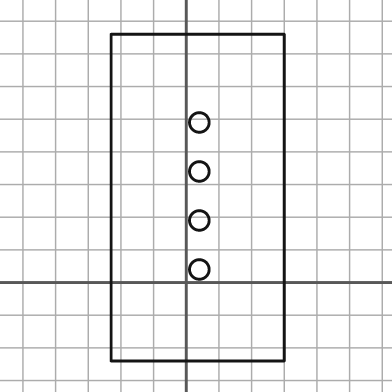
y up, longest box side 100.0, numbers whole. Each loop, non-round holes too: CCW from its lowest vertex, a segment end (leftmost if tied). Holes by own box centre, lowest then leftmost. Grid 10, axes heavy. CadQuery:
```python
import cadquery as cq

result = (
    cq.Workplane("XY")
    .moveTo(-23.0, -24.0)
    .lineTo(30.0, -24.0)
    .lineTo(30.0, 76.0)
    .lineTo(-23.0, 76.0)
    .close()
    .moveTo(4.0, 4.0)
    .circle(3.0)
    .moveTo(4.0, 19.0)
    .circle(3.0)
    .moveTo(4.0, 34.0)
    .circle(3.0)
    .moveTo(4.0, 49.0)
    .circle(3.0)
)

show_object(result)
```